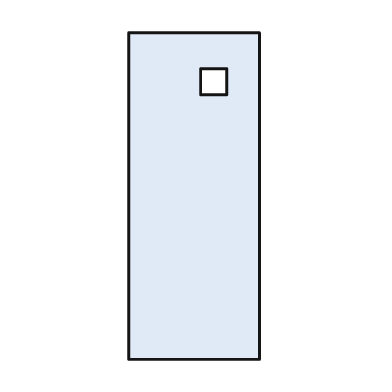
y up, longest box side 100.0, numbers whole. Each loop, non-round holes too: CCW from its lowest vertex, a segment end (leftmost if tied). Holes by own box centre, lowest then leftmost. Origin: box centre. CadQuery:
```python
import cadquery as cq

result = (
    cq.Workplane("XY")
    .moveTo(-20.0, -50.0)
    .lineTo(20.0, -50.0)
    .lineTo(20.0, 50.0)
    .lineTo(-20.0, 50.0)
    .close()
    .moveTo(2.0, 31.0)
    .lineTo(10.0, 31.0)
    .lineTo(10.0, 39.0)
    .lineTo(2.0, 39.0)
    .close()
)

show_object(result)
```